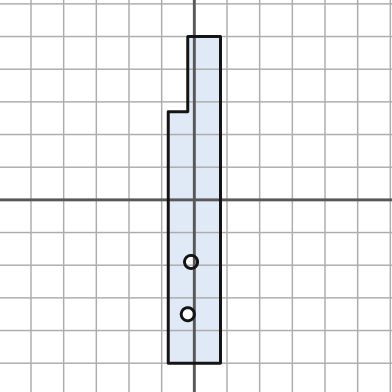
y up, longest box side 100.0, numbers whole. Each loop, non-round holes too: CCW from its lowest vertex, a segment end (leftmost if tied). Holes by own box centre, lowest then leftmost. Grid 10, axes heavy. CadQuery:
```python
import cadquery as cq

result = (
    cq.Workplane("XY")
    .moveTo(-8.0, -50.0)
    .lineTo(8.0, -50.0)
    .lineTo(8.0, 50.0)
    .lineTo(-2.0, 50.0)
    .lineTo(-2.0, 27.0)
    .lineTo(-8.0, 27.0)
    .close()
    .moveTo(-2.0, -35.0)
    .circle(2.0)
    .moveTo(-1.0, -19.0)
    .circle(2.0)
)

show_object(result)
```